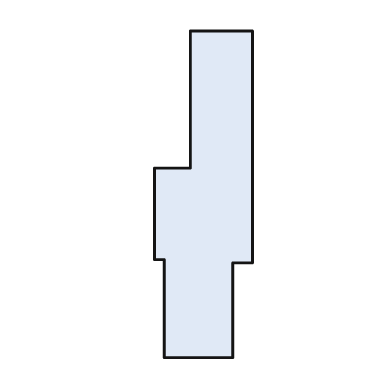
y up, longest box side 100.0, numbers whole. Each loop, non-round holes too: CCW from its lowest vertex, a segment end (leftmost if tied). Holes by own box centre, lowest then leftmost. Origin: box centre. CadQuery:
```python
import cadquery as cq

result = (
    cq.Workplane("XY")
    .moveTo(-12.0, -50.0)
    .lineTo(9.0, -50.0)
    .lineTo(9.0, -21.0)
    .lineTo(15.0, -21.0)
    .lineTo(15.0, 50.0)
    .lineTo(-4.0, 50.0)
    .lineTo(-4.0, 8.0)
    .lineTo(-15.0, 8.0)
    .lineTo(-15.0, -20.0)
    .lineTo(-12.0, -20.0)
    .close()
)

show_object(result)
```